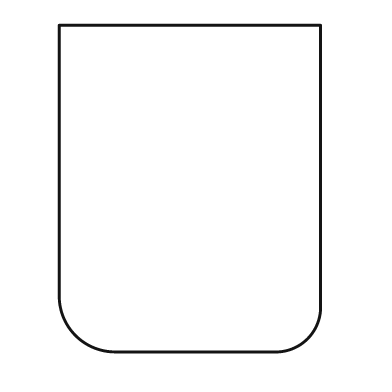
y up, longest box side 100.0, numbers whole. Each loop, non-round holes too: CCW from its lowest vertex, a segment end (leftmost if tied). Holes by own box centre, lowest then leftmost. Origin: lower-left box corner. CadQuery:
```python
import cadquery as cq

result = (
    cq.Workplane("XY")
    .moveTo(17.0, 0.0)
    .lineTo(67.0, 0.0)
    .threePointArc((76.0, 4.0), (80.0, 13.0))
    .lineTo(80.0, 100.0)
    .lineTo(0.0, 100.0)
    .lineTo(0.0, 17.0)
    .threePointArc((5.0, 5.0), (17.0, 0.0))
    .close()
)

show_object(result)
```